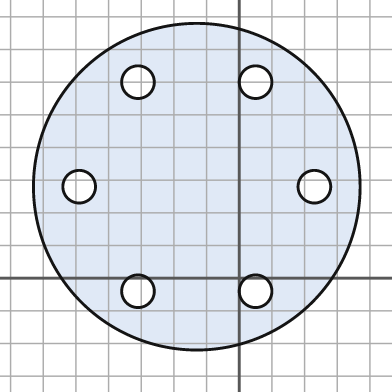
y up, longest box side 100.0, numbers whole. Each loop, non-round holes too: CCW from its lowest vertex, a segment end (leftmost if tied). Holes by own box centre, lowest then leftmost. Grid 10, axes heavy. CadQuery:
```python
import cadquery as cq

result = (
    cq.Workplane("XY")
    .moveTo(-13.0, 28.0)
    .circle(50.0)
    .moveTo(-31.0, -4.0)
    .circle(5.0)
    .moveTo(5.0, -4.0)
    .circle(5.0)
    .moveTo(-49.0, 28.0)
    .circle(5.0)
    .moveTo(23.0, 28.0)
    .circle(5.0)
    .moveTo(-31.0, 60.0)
    .circle(5.0)
    .moveTo(5.0, 60.0)
    .circle(5.0)
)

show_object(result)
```